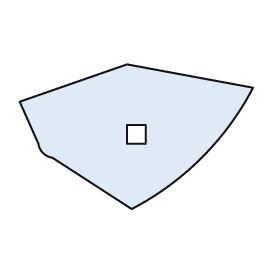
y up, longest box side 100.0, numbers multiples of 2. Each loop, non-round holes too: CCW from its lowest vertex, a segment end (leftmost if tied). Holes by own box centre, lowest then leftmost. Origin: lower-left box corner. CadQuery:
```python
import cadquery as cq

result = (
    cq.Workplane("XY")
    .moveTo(48.0, 0.0)
    .threePointArc((78.0, 22.0), (100.0, 52.0))
    .lineTo(46.0, 62.0)
    .lineTo(0.0, 46.0)
    .lineTo(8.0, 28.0)
    .threePointArc((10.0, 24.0), (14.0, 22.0))
    .close()
    .moveTo(46.0, 28.0)
    .lineTo(54.0, 28.0)
    .lineTo(54.0, 36.0)
    .lineTo(46.0, 36.0)
    .close()
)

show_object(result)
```